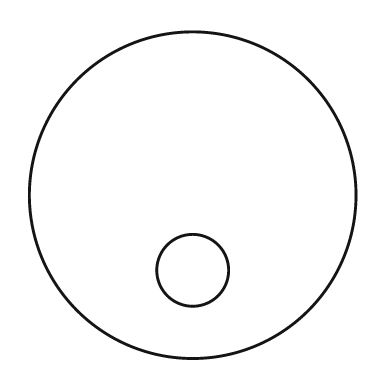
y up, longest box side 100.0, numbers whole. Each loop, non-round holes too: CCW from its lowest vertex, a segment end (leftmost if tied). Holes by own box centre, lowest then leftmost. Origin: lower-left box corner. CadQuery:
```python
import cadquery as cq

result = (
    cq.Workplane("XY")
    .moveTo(50.0, 50.0)
    .circle(50.0)
    .moveTo(50.0, 27.0)
    .circle(11.0)
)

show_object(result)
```